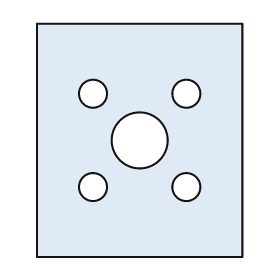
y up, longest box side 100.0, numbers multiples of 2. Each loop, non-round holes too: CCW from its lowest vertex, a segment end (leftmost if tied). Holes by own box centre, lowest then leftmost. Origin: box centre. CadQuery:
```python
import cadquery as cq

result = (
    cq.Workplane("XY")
    .moveTo(-44.0, -50.0)
    .lineTo(44.0, -50.0)
    .lineTo(44.0, 50.0)
    .lineTo(-44.0, 50.0)
    .close()
    .moveTo(-20.0, -20.0)
    .circle(6.0)
    .moveTo(20.0, -20.0)
    .circle(6.0)
    .moveTo(0.0, 0.0)
    .circle(12.0)
    .moveTo(-20.0, 20.0)
    .circle(6.0)
    .moveTo(20.0, 20.0)
    .circle(6.0)
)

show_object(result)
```